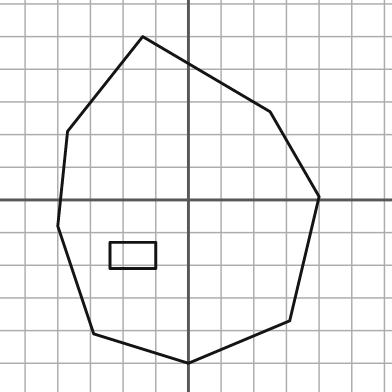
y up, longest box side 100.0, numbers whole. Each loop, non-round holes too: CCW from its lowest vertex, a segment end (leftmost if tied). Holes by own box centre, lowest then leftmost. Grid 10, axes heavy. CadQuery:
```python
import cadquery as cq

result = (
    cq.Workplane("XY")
    .moveTo(0.0, -50.0)
    .lineTo(31.0, -37.0)
    .lineTo(40.0, 1.0)
    .lineTo(25.0, 27.0)
    .lineTo(-14.0, 50.0)
    .lineTo(-37.0, 21.0)
    .lineTo(-40.0, -8.0)
    .lineTo(-29.0, -41.0)
    .close()
    .moveTo(-24.0, -21.0)
    .lineTo(-10.0, -21.0)
    .lineTo(-10.0, -13.0)
    .lineTo(-24.0, -13.0)
    .close()
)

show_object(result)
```